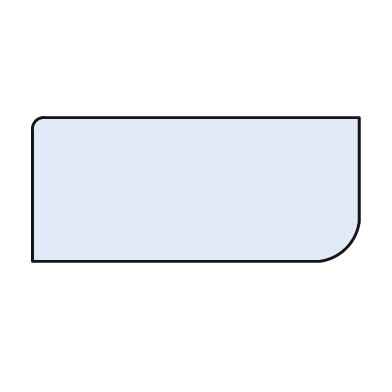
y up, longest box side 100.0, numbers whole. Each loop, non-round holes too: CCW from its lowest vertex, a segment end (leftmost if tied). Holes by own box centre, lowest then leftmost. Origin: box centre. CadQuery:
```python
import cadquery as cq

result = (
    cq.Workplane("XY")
    .moveTo(-50.0, -22.0)
    .lineTo(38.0, -22.0)
    .threePointArc((46.0, -18.0), (50.0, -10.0))
    .lineTo(50.0, 22.0)
    .lineTo(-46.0, 22.0)
    .threePointArc((-49.0, 21.0), (-50.0, 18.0))
    .close()
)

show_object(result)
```